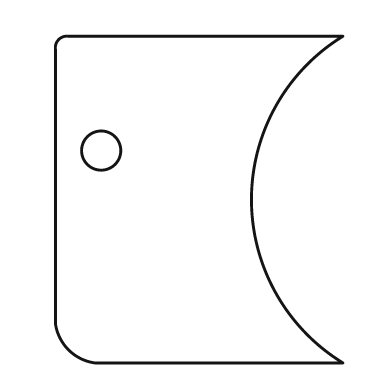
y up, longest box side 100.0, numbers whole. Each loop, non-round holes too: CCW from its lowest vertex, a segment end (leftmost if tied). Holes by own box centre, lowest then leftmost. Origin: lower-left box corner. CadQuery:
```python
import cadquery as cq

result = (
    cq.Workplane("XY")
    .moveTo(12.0, 0.0)
    .lineTo(88.0, 0.0)
    .threePointArc((60.0, 50.0), (88.0, 100.0))
    .lineTo(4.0, 100.0)
    .threePointArc((1.0, 99.0), (0.0, 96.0))
    .lineTo(0.0, 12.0)
    .threePointArc((4.0, 4.0), (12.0, 0.0))
    .close()
    .moveTo(14.0, 65.0)
    .circle(6.0)
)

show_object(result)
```